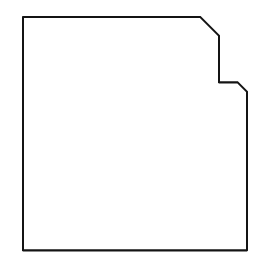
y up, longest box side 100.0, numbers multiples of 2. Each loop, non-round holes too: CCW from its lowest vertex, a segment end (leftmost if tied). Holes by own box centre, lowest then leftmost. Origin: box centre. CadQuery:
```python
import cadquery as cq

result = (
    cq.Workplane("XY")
    .moveTo(-48.0, -50.0)
    .lineTo(48.0, -50.0)
    .lineTo(48.0, 18.0)
    .lineTo(44.0, 22.0)
    .lineTo(36.0, 22.0)
    .lineTo(36.0, 42.0)
    .lineTo(28.0, 50.0)
    .lineTo(-48.0, 50.0)
    .close()
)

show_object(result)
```